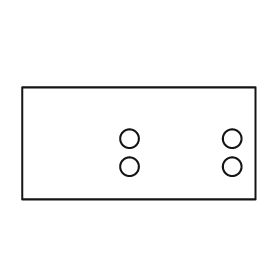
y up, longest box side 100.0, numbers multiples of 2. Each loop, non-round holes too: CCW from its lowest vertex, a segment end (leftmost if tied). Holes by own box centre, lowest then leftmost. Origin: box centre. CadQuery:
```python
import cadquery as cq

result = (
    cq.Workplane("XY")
    .moveTo(-50.0, -24.0)
    .lineTo(50.0, -24.0)
    .lineTo(50.0, 24.0)
    .lineTo(-50.0, 24.0)
    .close()
    .moveTo(-4.0, -10.0)
    .circle(4.0)
    .moveTo(40.0, -10.0)
    .circle(4.0)
    .moveTo(-4.0, 2.0)
    .circle(4.0)
    .moveTo(40.0, 2.0)
    .circle(4.0)
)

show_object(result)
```